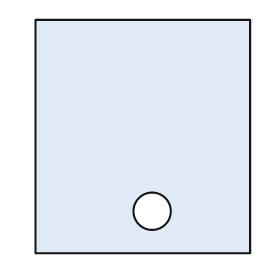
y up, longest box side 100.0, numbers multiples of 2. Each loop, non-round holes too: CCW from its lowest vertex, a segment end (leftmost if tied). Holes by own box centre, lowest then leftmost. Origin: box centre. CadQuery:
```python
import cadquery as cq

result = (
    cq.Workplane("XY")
    .moveTo(-46.0, -50.0)
    .lineTo(46.0, -50.0)
    .lineTo(46.0, 50.0)
    .lineTo(-46.0, 50.0)
    .close()
    .moveTo(4.0, -32.0)
    .circle(8.0)
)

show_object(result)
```